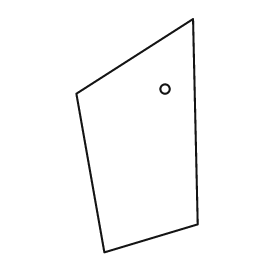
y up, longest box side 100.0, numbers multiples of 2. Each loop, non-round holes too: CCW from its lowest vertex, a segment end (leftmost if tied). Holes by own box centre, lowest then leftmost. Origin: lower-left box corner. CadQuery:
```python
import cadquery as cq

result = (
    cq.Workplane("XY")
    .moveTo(12.0, 0.0)
    .lineTo(52.0, 12.0)
    .lineTo(50.0, 100.0)
    .lineTo(0.0, 68.0)
    .close()
    .moveTo(38.0, 70.0)
    .circle(2.0)
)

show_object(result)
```